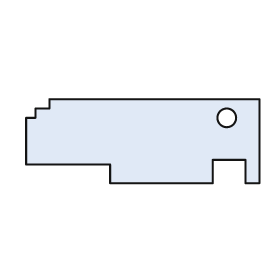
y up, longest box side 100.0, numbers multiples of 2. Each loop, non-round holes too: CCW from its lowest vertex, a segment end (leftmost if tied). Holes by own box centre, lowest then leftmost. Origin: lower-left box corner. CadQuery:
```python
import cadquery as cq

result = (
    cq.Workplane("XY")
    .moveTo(36.0, 0.0)
    .lineTo(80.0, 0.0)
    .lineTo(80.0, 10.0)
    .lineTo(94.0, 10.0)
    .lineTo(94.0, 0.0)
    .lineTo(100.0, 0.0)
    .lineTo(100.0, 36.0)
    .lineTo(10.0, 36.0)
    .lineTo(10.0, 32.0)
    .lineTo(4.0, 32.0)
    .lineTo(4.0, 28.0)
    .lineTo(0.0, 28.0)
    .lineTo(0.0, 8.0)
    .lineTo(36.0, 8.0)
    .close()
    .moveTo(86.0, 28.0)
    .circle(4.0)
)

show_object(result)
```